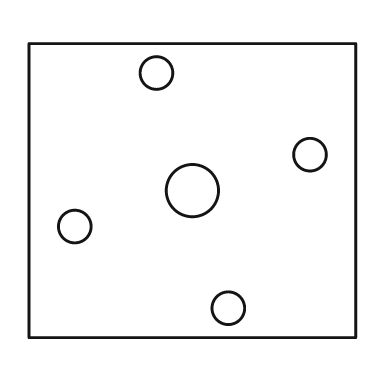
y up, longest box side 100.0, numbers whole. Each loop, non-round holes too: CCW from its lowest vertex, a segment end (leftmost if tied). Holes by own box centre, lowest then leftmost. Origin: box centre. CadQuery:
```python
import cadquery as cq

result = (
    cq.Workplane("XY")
    .moveTo(-50.0, -45.0)
    .lineTo(50.0, -45.0)
    .lineTo(50.0, 45.0)
    .lineTo(-50.0, 45.0)
    .close()
    .moveTo(11.0, -36.0)
    .circle(5.0)
    .moveTo(-36.0, -11.0)
    .circle(5.0)
    .moveTo(0.0, 0.0)
    .circle(8.0)
    .moveTo(36.0, 11.0)
    .circle(5.0)
    .moveTo(-11.0, 36.0)
    .circle(5.0)
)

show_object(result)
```